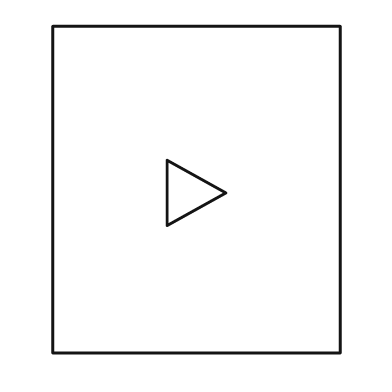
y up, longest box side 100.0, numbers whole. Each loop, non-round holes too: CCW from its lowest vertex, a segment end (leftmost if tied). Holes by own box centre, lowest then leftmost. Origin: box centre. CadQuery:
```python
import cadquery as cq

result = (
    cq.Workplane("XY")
    .moveTo(-44.0, -50.0)
    .lineTo(44.0, -50.0)
    .lineTo(44.0, 50.0)
    .lineTo(-44.0, 50.0)
    .close()
    .moveTo(-9.0, -11.0)
    .lineTo(9.0, -1.0)
    .lineTo(-9.0, 9.0)
    .close()
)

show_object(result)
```